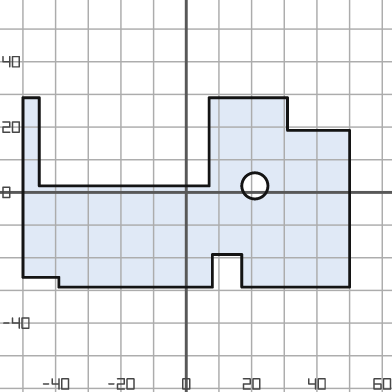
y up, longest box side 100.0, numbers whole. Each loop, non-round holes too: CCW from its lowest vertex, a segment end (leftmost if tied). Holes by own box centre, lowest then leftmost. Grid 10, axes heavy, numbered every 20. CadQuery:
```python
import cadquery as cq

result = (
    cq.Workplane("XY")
    .moveTo(-39.0, -29.0)
    .lineTo(8.0, -29.0)
    .lineTo(8.0, -19.0)
    .lineTo(17.0, -19.0)
    .lineTo(17.0, -29.0)
    .lineTo(50.0, -29.0)
    .lineTo(50.0, 19.0)
    .lineTo(31.0, 19.0)
    .lineTo(31.0, 29.0)
    .lineTo(7.0, 29.0)
    .lineTo(7.0, 2.0)
    .lineTo(-45.0, 2.0)
    .lineTo(-45.0, 29.0)
    .lineTo(-50.0, 29.0)
    .lineTo(-50.0, -26.0)
    .lineTo(-39.0, -26.0)
    .close()
    .moveTo(21.0, 2.0)
    .circle(4.0)
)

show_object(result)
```